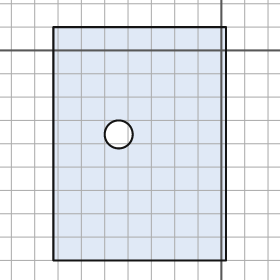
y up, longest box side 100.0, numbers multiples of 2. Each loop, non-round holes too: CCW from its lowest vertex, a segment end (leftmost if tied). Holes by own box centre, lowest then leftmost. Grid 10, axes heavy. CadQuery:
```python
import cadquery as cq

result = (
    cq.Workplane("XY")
    .moveTo(-72.0, -90.0)
    .lineTo(2.0, -90.0)
    .lineTo(2.0, 10.0)
    .lineTo(-72.0, 10.0)
    .close()
    .moveTo(-44.0, -36.0)
    .circle(6.0)
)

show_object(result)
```